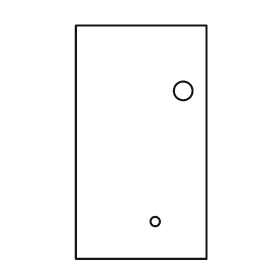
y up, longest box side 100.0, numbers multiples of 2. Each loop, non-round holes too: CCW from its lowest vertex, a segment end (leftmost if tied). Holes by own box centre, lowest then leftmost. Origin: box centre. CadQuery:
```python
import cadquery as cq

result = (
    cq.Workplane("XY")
    .moveTo(-28.0, -50.0)
    .lineTo(28.0, -50.0)
    .lineTo(28.0, 50.0)
    .lineTo(-28.0, 50.0)
    .close()
    .moveTo(6.0, -34.0)
    .circle(2.0)
    .moveTo(18.0, 22.0)
    .circle(4.0)
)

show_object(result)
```